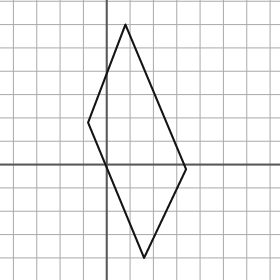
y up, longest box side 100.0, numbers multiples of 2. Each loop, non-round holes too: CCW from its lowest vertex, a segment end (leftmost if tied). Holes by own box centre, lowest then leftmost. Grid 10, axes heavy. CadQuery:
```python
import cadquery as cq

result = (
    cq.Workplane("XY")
    .moveTo(16.0, -40.0)
    .lineTo(34.0, -2.0)
    .lineTo(8.0, 60.0)
    .lineTo(-8.0, 18.0)
    .close()
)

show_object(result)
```